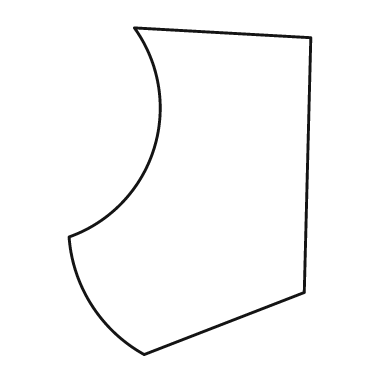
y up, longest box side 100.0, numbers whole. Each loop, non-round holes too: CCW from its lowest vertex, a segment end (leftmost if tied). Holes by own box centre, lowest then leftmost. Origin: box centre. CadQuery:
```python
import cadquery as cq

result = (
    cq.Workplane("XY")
    .moveTo(-14.0, -50.0)
    .lineTo(35.0, -31.0)
    .lineTo(37.0, 47.0)
    .lineTo(-17.0, 50.0)
    .threePointArc((-11.0, 13.0), (-37.0, -14.0))
    .threePointArc((-30.0, -35.0), (-14.0, -50.0))
    .close()
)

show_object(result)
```